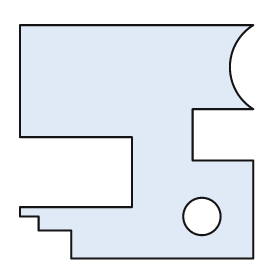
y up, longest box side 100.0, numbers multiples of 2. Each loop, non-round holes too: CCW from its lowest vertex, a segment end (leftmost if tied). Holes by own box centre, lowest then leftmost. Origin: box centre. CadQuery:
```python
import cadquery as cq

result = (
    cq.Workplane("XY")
    .moveTo(-28.0, -50.0)
    .lineTo(50.0, -50.0)
    .lineTo(50.0, -8.0)
    .lineTo(24.0, -8.0)
    .lineTo(24.0, 14.0)
    .lineTo(50.0, 14.0)
    .threePointArc((40.0, 32.0), (50.0, 50.0))
    .lineTo(-50.0, 50.0)
    .lineTo(-50.0, 2.0)
    .lineTo(-2.0, 2.0)
    .lineTo(-2.0, -28.0)
    .lineTo(-50.0, -28.0)
    .lineTo(-50.0, -32.0)
    .lineTo(-42.0, -32.0)
    .lineTo(-42.0, -38.0)
    .lineTo(-28.0, -38.0)
    .close()
    .moveTo(28.0, -32.0)
    .circle(8.0)
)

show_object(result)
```